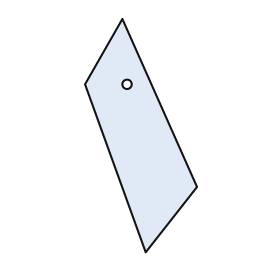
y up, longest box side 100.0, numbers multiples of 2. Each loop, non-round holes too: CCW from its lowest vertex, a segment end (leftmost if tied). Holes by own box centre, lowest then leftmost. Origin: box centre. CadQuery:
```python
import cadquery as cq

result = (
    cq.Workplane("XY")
    .moveTo(2.0, -50.0)
    .lineTo(24.0, -22.0)
    .lineTo(-8.0, 50.0)
    .lineTo(-24.0, 22.0)
    .close()
    .moveTo(-6.0, 22.0)
    .circle(2.0)
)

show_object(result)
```